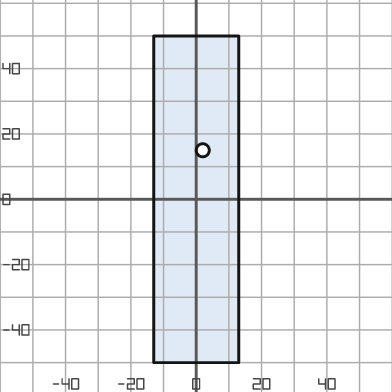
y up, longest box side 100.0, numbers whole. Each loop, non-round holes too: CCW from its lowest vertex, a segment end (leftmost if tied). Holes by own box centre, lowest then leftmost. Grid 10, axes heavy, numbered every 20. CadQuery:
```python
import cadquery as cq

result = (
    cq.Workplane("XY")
    .moveTo(-13.0, -50.0)
    .lineTo(13.0, -50.0)
    .lineTo(13.0, 50.0)
    .lineTo(-13.0, 50.0)
    .close()
    .moveTo(2.0, 15.0)
    .circle(2.0)
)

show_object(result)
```